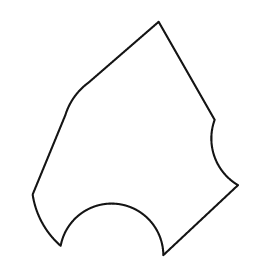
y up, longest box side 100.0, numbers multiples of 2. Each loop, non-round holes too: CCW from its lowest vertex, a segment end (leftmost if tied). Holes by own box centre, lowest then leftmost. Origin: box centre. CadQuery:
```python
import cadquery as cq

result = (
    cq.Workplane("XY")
    .moveTo(12.0, -50.0)
    .lineTo(44.0, -20.0)
    .threePointArc((34.0, -8.0), (34.0, 8.0))
    .lineTo(10.0, 50.0)
    .lineTo(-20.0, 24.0)
    .threePointArc((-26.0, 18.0), (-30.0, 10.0))
    .lineTo(-44.0, -24.0)
    .threePointArc((-40.0, -36.0), (-32.0, -46.0))
    .threePointArc((-8.0, -28.0), (12.0, -50.0))
    .close()
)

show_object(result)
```